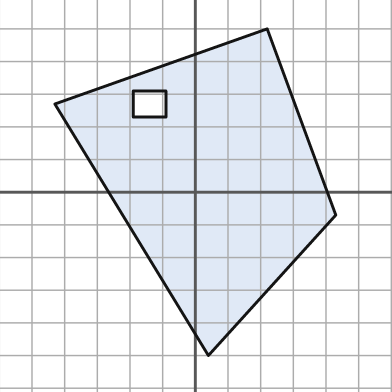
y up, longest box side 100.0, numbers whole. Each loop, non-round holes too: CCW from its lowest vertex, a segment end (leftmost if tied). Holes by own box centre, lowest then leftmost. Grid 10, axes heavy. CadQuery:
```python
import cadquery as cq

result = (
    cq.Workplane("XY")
    .moveTo(4.0, -50.0)
    .lineTo(43.0, -7.0)
    .lineTo(22.0, 50.0)
    .lineTo(-43.0, 27.0)
    .close()
    .moveTo(-19.0, 23.0)
    .lineTo(-9.0, 23.0)
    .lineTo(-9.0, 31.0)
    .lineTo(-19.0, 31.0)
    .close()
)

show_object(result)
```